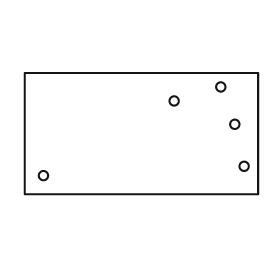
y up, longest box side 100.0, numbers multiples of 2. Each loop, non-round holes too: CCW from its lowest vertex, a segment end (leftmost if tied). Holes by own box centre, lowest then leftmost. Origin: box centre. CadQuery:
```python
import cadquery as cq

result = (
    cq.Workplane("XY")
    .moveTo(-50.0, -26.0)
    .lineTo(50.0, -26.0)
    .lineTo(50.0, 26.0)
    .lineTo(-50.0, 26.0)
    .close()
    .moveTo(-42.0, -18.0)
    .circle(2.0)
    .moveTo(44.0, -14.0)
    .circle(2.0)
    .moveTo(40.0, 4.0)
    .circle(2.0)
    .moveTo(14.0, 14.0)
    .circle(2.0)
    .moveTo(34.0, 20.0)
    .circle(2.0)
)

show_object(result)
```